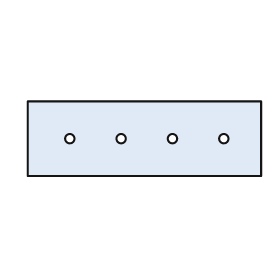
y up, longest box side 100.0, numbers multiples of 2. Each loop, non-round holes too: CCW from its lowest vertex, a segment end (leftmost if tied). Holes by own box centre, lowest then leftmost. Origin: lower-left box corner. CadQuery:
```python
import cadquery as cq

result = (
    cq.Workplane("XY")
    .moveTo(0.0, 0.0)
    .lineTo(100.0, 0.0)
    .lineTo(100.0, 32.0)
    .lineTo(0.0, 32.0)
    .close()
    .moveTo(18.0, 16.0)
    .circle(2.0)
    .moveTo(40.0, 16.0)
    .circle(2.0)
    .moveTo(62.0, 16.0)
    .circle(2.0)
    .moveTo(84.0, 16.0)
    .circle(2.0)
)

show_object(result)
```